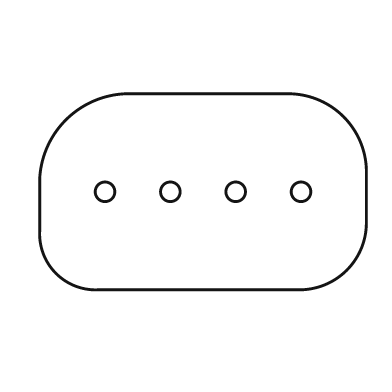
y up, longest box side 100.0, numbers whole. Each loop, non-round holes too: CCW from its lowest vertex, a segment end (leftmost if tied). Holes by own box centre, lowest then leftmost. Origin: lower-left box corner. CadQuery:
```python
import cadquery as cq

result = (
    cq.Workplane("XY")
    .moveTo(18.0, 0.0)
    .lineTo(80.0, 0.0)
    .threePointArc((94.0, 6.0), (100.0, 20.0))
    .lineTo(100.0, 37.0)
    .threePointArc((93.0, 53.0), (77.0, 60.0))
    .lineTo(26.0, 60.0)
    .threePointArc((8.0, 52.0), (0.0, 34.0))
    .lineTo(0.0, 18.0)
    .threePointArc((5.0, 5.0), (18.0, 0.0))
    .close()
    .moveTo(20.0, 30.0)
    .circle(3.0)
    .moveTo(40.0, 30.0)
    .circle(3.0)
    .moveTo(60.0, 30.0)
    .circle(3.0)
    .moveTo(80.0, 30.0)
    .circle(3.0)
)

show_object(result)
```